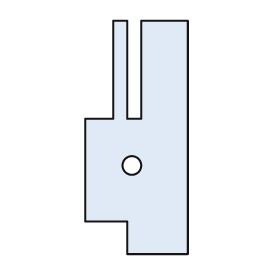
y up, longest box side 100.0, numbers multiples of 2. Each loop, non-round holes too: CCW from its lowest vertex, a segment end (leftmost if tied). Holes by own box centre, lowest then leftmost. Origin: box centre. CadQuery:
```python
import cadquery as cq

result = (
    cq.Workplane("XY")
    .moveTo(-4.0, -50.0)
    .lineTo(22.0, -50.0)
    .lineTo(22.0, 50.0)
    .lineTo(2.0, 50.0)
    .lineTo(2.0, 8.0)
    .lineTo(-4.0, 8.0)
    .lineTo(-4.0, 50.0)
    .lineTo(-10.0, 50.0)
    .lineTo(-10.0, 8.0)
    .lineTo(-22.0, 8.0)
    .lineTo(-22.0, -36.0)
    .lineTo(-4.0, -36.0)
    .close()
    .moveTo(-2.0, -12.0)
    .circle(4.0)
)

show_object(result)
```